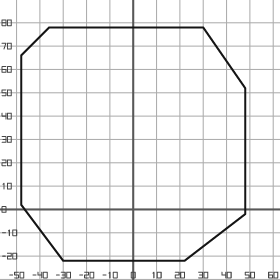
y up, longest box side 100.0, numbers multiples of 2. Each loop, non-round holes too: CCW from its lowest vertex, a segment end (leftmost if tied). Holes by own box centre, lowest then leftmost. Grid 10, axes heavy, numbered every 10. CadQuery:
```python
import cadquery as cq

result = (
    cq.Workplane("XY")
    .moveTo(-30.0, -22.0)
    .lineTo(22.0, -22.0)
    .lineTo(48.0, -2.0)
    .lineTo(48.0, 52.0)
    .lineTo(30.0, 78.0)
    .lineTo(-36.0, 78.0)
    .lineTo(-48.0, 66.0)
    .lineTo(-48.0, 2.0)
    .close()
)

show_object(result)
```